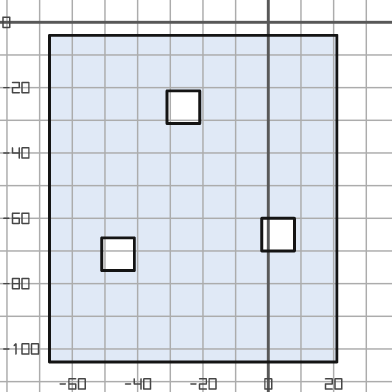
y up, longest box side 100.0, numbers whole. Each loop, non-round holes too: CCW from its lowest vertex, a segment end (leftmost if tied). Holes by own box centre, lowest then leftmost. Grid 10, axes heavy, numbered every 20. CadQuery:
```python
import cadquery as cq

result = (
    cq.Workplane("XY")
    .moveTo(-67.0, -104.0)
    .lineTo(21.0, -104.0)
    .lineTo(21.0, -4.0)
    .lineTo(-67.0, -4.0)
    .close()
    .moveTo(-51.0, -76.0)
    .lineTo(-41.0, -76.0)
    .lineTo(-41.0, -66.0)
    .lineTo(-51.0, -66.0)
    .close()
    .moveTo(-2.0, -70.0)
    .lineTo(8.0, -70.0)
    .lineTo(8.0, -60.0)
    .lineTo(-2.0, -60.0)
    .close()
    .moveTo(-31.0, -31.0)
    .lineTo(-21.0, -31.0)
    .lineTo(-21.0, -21.0)
    .lineTo(-31.0, -21.0)
    .close()
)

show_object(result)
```